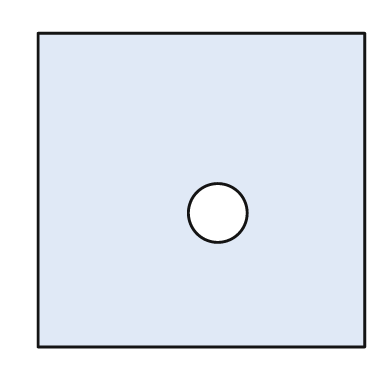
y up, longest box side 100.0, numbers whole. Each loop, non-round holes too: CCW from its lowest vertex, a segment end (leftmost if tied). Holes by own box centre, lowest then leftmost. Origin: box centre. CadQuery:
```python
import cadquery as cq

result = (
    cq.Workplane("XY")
    .moveTo(-50.0, -48.0)
    .lineTo(50.0, -48.0)
    .lineTo(50.0, 48.0)
    .lineTo(-50.0, 48.0)
    .close()
    .moveTo(5.0, -7.0)
    .circle(9.0)
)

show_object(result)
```